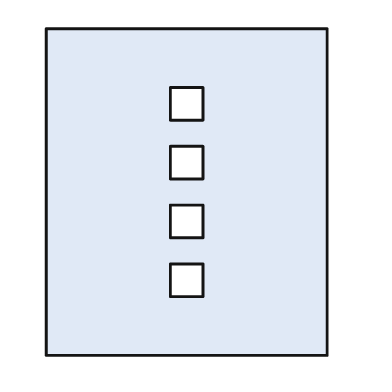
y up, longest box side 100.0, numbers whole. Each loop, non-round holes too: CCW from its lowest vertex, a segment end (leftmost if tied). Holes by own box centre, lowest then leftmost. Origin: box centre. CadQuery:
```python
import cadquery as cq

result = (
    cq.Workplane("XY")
    .moveTo(-43.0, -50.0)
    .lineTo(43.0, -50.0)
    .lineTo(43.0, 50.0)
    .lineTo(-43.0, 50.0)
    .close()
    .moveTo(-5.0, -32.0)
    .lineTo(5.0, -32.0)
    .lineTo(5.0, -22.0)
    .lineTo(-5.0, -22.0)
    .close()
    .moveTo(-5.0, -14.0)
    .lineTo(5.0, -14.0)
    .lineTo(5.0, -4.0)
    .lineTo(-5.0, -4.0)
    .close()
    .moveTo(-5.0, 4.0)
    .lineTo(5.0, 4.0)
    .lineTo(5.0, 14.0)
    .lineTo(-5.0, 14.0)
    .close()
    .moveTo(-5.0, 22.0)
    .lineTo(5.0, 22.0)
    .lineTo(5.0, 32.0)
    .lineTo(-5.0, 32.0)
    .close()
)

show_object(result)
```